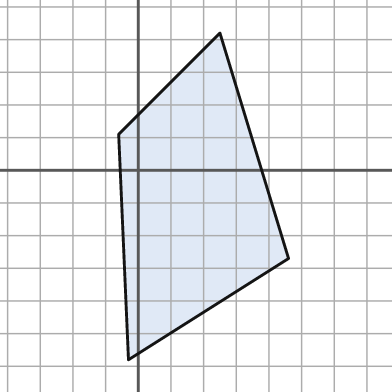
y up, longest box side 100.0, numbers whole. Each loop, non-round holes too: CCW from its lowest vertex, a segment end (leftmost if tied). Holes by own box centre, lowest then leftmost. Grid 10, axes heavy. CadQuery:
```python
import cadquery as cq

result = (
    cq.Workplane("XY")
    .moveTo(-3.0, -58.0)
    .lineTo(46.0, -27.0)
    .lineTo(25.0, 42.0)
    .lineTo(-6.0, 11.0)
    .close()
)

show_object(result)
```